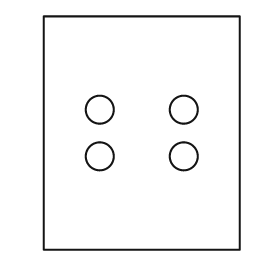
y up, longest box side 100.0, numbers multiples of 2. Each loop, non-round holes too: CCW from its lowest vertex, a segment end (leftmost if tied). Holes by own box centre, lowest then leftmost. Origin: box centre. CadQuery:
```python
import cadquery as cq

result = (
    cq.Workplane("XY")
    .moveTo(-42.0, -50.0)
    .lineTo(42.0, -50.0)
    .lineTo(42.0, 50.0)
    .lineTo(-42.0, 50.0)
    .close()
    .moveTo(-18.0, -10.0)
    .circle(6.0)
    .moveTo(18.0, -10.0)
    .circle(6.0)
    .moveTo(-18.0, 10.0)
    .circle(6.0)
    .moveTo(18.0, 10.0)
    .circle(6.0)
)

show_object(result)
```